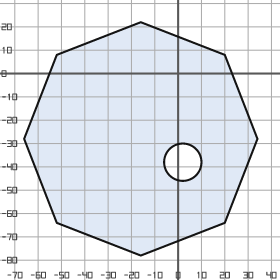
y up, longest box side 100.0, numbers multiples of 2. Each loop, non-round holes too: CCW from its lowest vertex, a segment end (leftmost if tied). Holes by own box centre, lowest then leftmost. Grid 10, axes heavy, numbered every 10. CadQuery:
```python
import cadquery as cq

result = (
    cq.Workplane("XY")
    .moveTo(-16.0, -78.0)
    .lineTo(20.0, -64.0)
    .lineTo(34.0, -28.0)
    .lineTo(20.0, 8.0)
    .lineTo(-16.0, 22.0)
    .lineTo(-52.0, 8.0)
    .lineTo(-66.0, -28.0)
    .lineTo(-52.0, -64.0)
    .close()
    .moveTo(2.0, -38.0)
    .circle(8.0)
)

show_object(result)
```